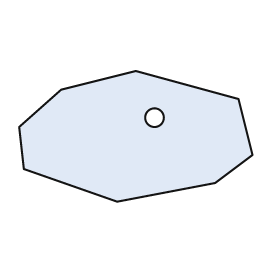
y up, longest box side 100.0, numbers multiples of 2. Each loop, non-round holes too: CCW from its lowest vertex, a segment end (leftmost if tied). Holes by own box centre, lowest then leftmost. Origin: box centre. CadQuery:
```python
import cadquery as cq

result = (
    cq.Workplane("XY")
    .moveTo(-8.0, -28.0)
    .lineTo(34.0, -20.0)
    .lineTo(50.0, -8.0)
    .lineTo(44.0, 16.0)
    .lineTo(0.0, 28.0)
    .lineTo(-32.0, 20.0)
    .lineTo(-50.0, 4.0)
    .lineTo(-48.0, -14.0)
    .close()
    .moveTo(8.0, 8.0)
    .circle(4.0)
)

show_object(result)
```